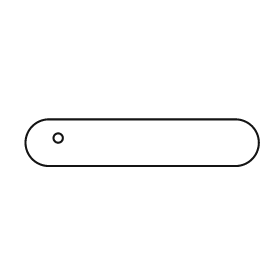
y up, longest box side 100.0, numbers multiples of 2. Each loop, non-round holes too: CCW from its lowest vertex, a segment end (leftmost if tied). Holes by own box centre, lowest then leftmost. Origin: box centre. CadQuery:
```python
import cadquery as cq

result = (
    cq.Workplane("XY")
    .moveTo(-40.0, -10.0)
    .lineTo(40.0, -10.0)
    .threePointArc((50.0, 0.0), (40.0, 10.0))
    .lineTo(-40.0, 10.0)
    .threePointArc((-50.0, 0.0), (-40.0, -10.0))
    .close()
    .moveTo(-36.0, 2.0)
    .circle(2.0)
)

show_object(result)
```